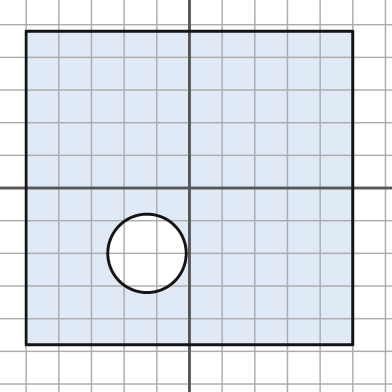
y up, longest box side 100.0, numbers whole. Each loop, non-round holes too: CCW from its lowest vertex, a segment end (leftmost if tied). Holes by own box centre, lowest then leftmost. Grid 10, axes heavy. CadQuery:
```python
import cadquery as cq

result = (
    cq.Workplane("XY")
    .moveTo(-50.0, -48.0)
    .lineTo(50.0, -48.0)
    .lineTo(50.0, 48.0)
    .lineTo(-50.0, 48.0)
    .close()
    .moveTo(-13.0, -20.0)
    .circle(12.0)
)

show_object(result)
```